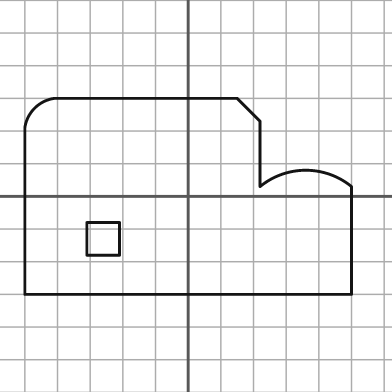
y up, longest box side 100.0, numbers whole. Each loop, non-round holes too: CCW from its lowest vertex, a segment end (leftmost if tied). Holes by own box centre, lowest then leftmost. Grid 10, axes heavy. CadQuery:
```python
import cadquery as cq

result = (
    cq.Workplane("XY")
    .moveTo(-50.0, -30.0)
    .lineTo(50.0, -30.0)
    .lineTo(50.0, 3.0)
    .threePointArc((36.0, 8.0), (22.0, 3.0))
    .lineTo(22.0, 23.0)
    .lineTo(15.0, 30.0)
    .lineTo(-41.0, 30.0)
    .threePointArc((-47.0, 27.0), (-50.0, 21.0))
    .close()
    .moveTo(-31.0, -18.0)
    .lineTo(-21.0, -18.0)
    .lineTo(-21.0, -8.0)
    .lineTo(-31.0, -8.0)
    .close()
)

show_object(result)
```